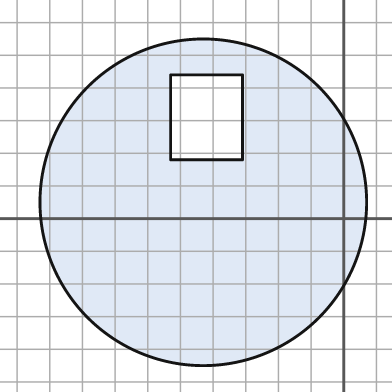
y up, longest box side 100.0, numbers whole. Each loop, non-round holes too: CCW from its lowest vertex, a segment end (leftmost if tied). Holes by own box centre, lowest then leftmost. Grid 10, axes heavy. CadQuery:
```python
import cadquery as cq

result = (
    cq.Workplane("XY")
    .moveTo(-43.0, 5.0)
    .circle(50.0)
    .moveTo(-53.0, 18.0)
    .lineTo(-31.0, 18.0)
    .lineTo(-31.0, 44.0)
    .lineTo(-53.0, 44.0)
    .close()
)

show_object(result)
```